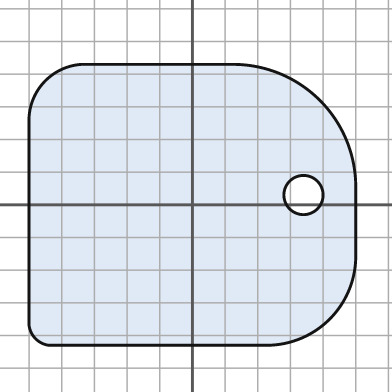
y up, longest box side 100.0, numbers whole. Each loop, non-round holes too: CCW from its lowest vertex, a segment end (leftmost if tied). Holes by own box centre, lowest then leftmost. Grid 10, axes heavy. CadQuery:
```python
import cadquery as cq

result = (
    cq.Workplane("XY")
    .moveTo(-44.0, -43.0)
    .lineTo(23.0, -43.0)
    .threePointArc((42.0, -35.0), (50.0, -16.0))
    .lineTo(50.0, 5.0)
    .threePointArc((39.0, 32.0), (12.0, 43.0))
    .lineTo(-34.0, 43.0)
    .threePointArc((-45.0, 38.0), (-50.0, 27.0))
    .lineTo(-50.0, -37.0)
    .threePointArc((-48.0, -41.0), (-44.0, -43.0))
    .close()
    .moveTo(34.0, 3.0)
    .circle(6.0)
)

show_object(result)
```